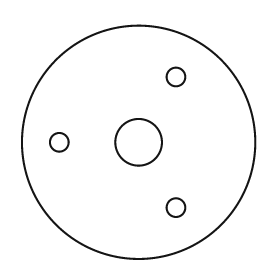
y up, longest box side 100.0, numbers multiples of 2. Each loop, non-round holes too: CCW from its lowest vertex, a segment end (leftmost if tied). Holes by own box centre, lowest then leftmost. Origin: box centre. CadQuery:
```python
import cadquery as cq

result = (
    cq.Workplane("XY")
    .moveTo(0.0, 0.0)
    .circle(50.0)
    .moveTo(16.0, -28.0)
    .circle(4.0)
    .moveTo(-34.0, 0.0)
    .circle(4.0)
    .moveTo(0.0, 0.0)
    .circle(10.0)
    .moveTo(16.0, 28.0)
    .circle(4.0)
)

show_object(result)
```